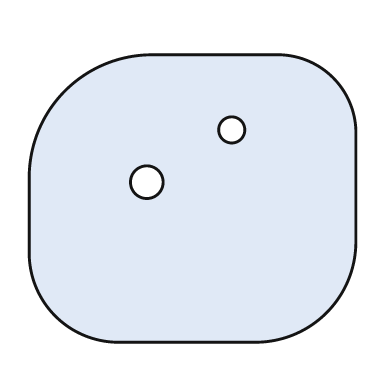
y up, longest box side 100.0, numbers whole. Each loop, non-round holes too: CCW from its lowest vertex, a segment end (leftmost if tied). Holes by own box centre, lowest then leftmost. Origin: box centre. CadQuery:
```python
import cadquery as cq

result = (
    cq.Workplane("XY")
    .moveTo(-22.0, -44.0)
    .lineTo(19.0, -44.0)
    .threePointArc((41.0, -35.0), (50.0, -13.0))
    .lineTo(50.0, 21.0)
    .threePointArc((43.0, 37.0), (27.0, 44.0))
    .lineTo(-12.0, 44.0)
    .threePointArc((-39.0, 33.0), (-50.0, 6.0))
    .lineTo(-50.0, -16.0)
    .threePointArc((-42.0, -36.0), (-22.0, -44.0))
    .close()
    .moveTo(-14.0, 5.0)
    .circle(5.0)
    .moveTo(12.0, 21.0)
    .circle(4.0)
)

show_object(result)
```